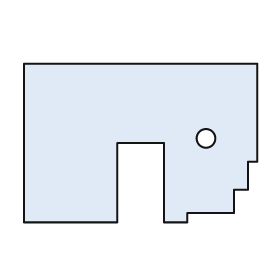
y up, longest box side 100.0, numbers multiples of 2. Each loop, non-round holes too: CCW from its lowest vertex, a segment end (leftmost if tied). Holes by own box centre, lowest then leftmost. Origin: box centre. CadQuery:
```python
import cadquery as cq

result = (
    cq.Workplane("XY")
    .moveTo(-50.0, -34.0)
    .lineTo(-10.0, -34.0)
    .lineTo(-10.0, 0.0)
    .lineTo(10.0, 0.0)
    .lineTo(10.0, -34.0)
    .lineTo(20.0, -34.0)
    .lineTo(20.0, -30.0)
    .lineTo(40.0, -30.0)
    .lineTo(40.0, -20.0)
    .lineTo(46.0, -20.0)
    .lineTo(46.0, -8.0)
    .lineTo(50.0, -8.0)
    .lineTo(50.0, 34.0)
    .lineTo(-50.0, 34.0)
    .close()
    .moveTo(28.0, 2.0)
    .circle(4.0)
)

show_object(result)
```